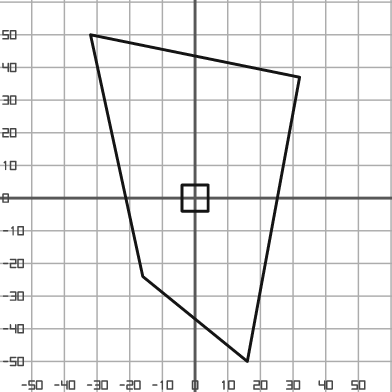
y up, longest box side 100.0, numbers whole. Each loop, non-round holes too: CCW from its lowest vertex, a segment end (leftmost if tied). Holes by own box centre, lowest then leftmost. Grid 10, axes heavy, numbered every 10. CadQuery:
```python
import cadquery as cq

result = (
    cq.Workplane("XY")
    .moveTo(16.0, -50.0)
    .lineTo(32.0, 37.0)
    .lineTo(-32.0, 50.0)
    .lineTo(-16.0, -24.0)
    .close()
    .moveTo(-4.0, -4.0)
    .lineTo(4.0, -4.0)
    .lineTo(4.0, 4.0)
    .lineTo(-4.0, 4.0)
    .close()
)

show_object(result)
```